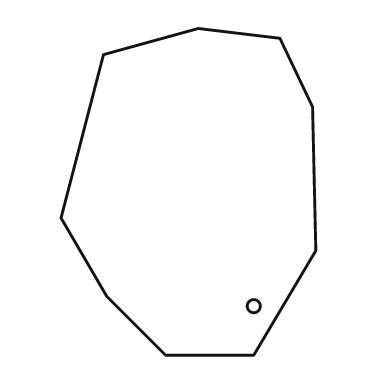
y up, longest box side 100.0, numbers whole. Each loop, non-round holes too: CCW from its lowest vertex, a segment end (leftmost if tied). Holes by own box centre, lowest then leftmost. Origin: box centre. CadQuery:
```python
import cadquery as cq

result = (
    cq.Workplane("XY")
    .moveTo(-7.0, -50.0)
    .lineTo(20.0, -50.0)
    .lineTo(39.0, -18.0)
    .lineTo(38.0, 26.0)
    .lineTo(28.0, 47.0)
    .lineTo(3.0, 50.0)
    .lineTo(-26.0, 42.0)
    .lineTo(-39.0, -8.0)
    .lineTo(-25.0, -32.0)
    .close()
    .moveTo(20.0, -35.0)
    .circle(2.0)
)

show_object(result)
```